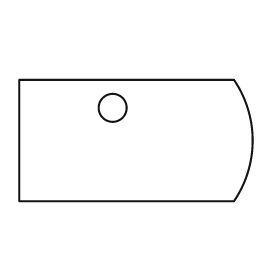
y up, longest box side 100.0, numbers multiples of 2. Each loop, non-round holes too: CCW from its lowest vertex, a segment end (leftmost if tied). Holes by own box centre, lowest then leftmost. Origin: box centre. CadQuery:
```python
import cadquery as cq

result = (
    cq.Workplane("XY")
    .moveTo(-50.0, -26.0)
    .lineTo(42.0, -26.0)
    .threePointArc((50.0, 0.0), (42.0, 26.0))
    .lineTo(-50.0, 26.0)
    .close()
    .moveTo(-10.0, 14.0)
    .circle(6.0)
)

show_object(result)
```